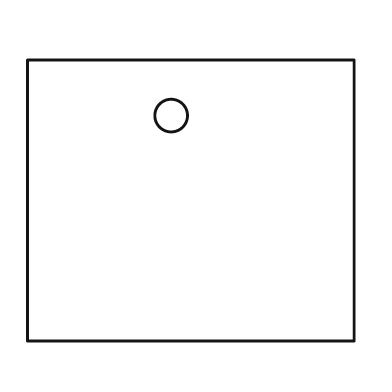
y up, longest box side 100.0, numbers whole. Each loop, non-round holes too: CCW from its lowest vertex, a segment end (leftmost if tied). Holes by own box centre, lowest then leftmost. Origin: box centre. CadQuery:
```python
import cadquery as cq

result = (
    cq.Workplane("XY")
    .moveTo(-50.0, -43.0)
    .lineTo(50.0, -43.0)
    .lineTo(50.0, 43.0)
    .lineTo(-50.0, 43.0)
    .close()
    .moveTo(-6.0, 26.0)
    .circle(5.0)
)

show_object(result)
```